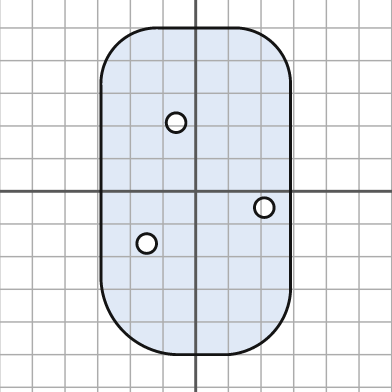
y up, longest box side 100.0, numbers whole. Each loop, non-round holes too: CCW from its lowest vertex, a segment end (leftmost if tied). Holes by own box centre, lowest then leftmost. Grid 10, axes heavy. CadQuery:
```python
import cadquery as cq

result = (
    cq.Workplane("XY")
    .moveTo(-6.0, -50.0)
    .lineTo(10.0, -50.0)
    .threePointArc((23.0, -44.0), (29.0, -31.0))
    .lineTo(29.0, 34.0)
    .threePointArc((24.0, 45.0), (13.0, 50.0))
    .lineTo(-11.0, 50.0)
    .threePointArc((-24.0, 45.0), (-29.0, 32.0))
    .lineTo(-29.0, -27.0)
    .threePointArc((-22.0, -43.0), (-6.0, -50.0))
    .close()
    .moveTo(-15.0, -16.0)
    .circle(3.0)
    .moveTo(21.0, -5.0)
    .circle(3.0)
    .moveTo(-6.0, 21.0)
    .circle(3.0)
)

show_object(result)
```